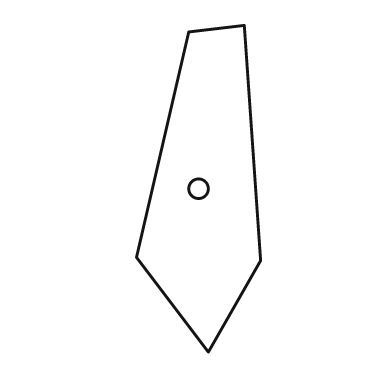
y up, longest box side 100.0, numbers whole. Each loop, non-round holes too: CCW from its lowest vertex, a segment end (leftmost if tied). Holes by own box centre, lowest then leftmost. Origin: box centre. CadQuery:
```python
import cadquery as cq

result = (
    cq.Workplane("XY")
    .moveTo(3.0, -50.0)
    .lineTo(19.0, -22.0)
    .lineTo(14.0, 50.0)
    .lineTo(-3.0, 48.0)
    .lineTo(-19.0, -21.0)
    .close()
    .moveTo(0.0, 0.0)
    .circle(3.0)
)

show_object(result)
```